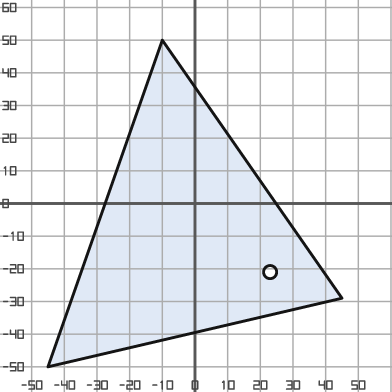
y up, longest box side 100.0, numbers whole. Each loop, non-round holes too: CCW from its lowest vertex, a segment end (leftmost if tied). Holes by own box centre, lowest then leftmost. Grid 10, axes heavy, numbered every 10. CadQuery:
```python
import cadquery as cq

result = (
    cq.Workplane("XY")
    .moveTo(-45.0, -50.0)
    .lineTo(45.0, -29.0)
    .lineTo(-10.0, 50.0)
    .close()
    .moveTo(23.0, -21.0)
    .circle(2.0)
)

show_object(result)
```